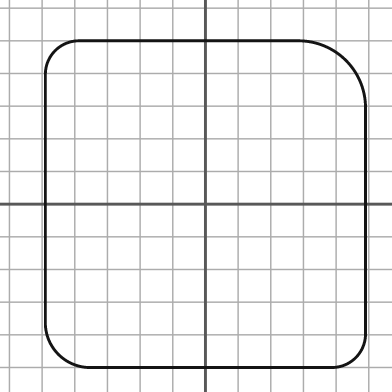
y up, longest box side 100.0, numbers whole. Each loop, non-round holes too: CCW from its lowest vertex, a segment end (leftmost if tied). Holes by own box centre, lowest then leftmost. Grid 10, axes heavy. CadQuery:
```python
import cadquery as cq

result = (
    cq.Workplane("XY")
    .moveTo(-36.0, -50.0)
    .lineTo(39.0, -50.0)
    .threePointArc((46.0, -47.0), (49.0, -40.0))
    .lineTo(49.0, 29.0)
    .threePointArc((43.0, 44.0), (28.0, 50.0))
    .lineTo(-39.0, 50.0)
    .threePointArc((-46.0, 47.0), (-49.0, 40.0))
    .lineTo(-49.0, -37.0)
    .threePointArc((-45.0, -46.0), (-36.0, -50.0))
    .close()
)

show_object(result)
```